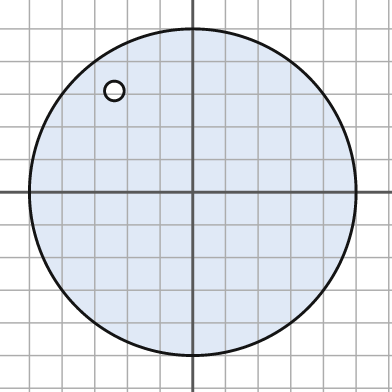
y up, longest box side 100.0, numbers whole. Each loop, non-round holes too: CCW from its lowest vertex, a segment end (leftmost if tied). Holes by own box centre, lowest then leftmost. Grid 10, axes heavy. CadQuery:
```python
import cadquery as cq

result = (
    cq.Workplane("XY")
    .moveTo(0.0, 0.0)
    .circle(50.0)
    .moveTo(-24.0, 31.0)
    .circle(3.0)
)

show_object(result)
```